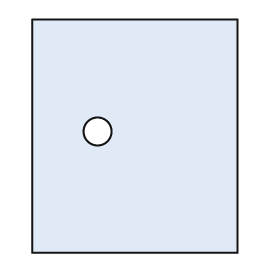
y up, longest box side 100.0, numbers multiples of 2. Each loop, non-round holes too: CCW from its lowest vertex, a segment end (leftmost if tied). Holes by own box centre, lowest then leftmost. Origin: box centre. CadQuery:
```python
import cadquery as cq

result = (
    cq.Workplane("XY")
    .moveTo(-44.0, -50.0)
    .lineTo(44.0, -50.0)
    .lineTo(44.0, 50.0)
    .lineTo(-44.0, 50.0)
    .close()
    .moveTo(-16.0, 2.0)
    .circle(6.0)
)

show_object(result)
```